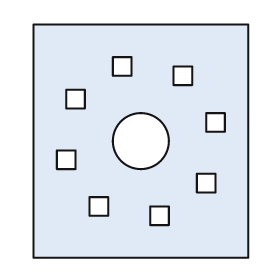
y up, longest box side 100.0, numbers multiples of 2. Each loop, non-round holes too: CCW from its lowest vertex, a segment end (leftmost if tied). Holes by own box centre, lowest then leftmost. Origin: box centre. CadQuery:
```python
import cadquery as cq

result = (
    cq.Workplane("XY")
    .moveTo(-46.0, -50.0)
    .lineTo(46.0, -50.0)
    .lineTo(46.0, 50.0)
    .lineTo(-46.0, 50.0)
    .close()
    .moveTo(4.0, -36.0)
    .lineTo(12.0, -36.0)
    .lineTo(12.0, -28.0)
    .lineTo(4.0, -28.0)
    .close()
    .moveTo(-22.0, -32.0)
    .lineTo(-14.0, -32.0)
    .lineTo(-14.0, -24.0)
    .lineTo(-22.0, -24.0)
    .close()
    .moveTo(24.0, -22.0)
    .lineTo(32.0, -22.0)
    .lineTo(32.0, -14.0)
    .lineTo(24.0, -14.0)
    .close()
    .moveTo(-36.0, -12.0)
    .lineTo(-28.0, -12.0)
    .lineTo(-28.0, -4.0)
    .lineTo(-36.0, -4.0)
    .close()
    .moveTo(0.0, 0.0)
    .circle(12.0)
    .moveTo(28.0, 4.0)
    .lineTo(36.0, 4.0)
    .lineTo(36.0, 12.0)
    .lineTo(28.0, 12.0)
    .close()
    .moveTo(-32.0, 14.0)
    .lineTo(-24.0, 14.0)
    .lineTo(-24.0, 22.0)
    .lineTo(-32.0, 22.0)
    .close()
    .moveTo(14.0, 24.0)
    .lineTo(22.0, 24.0)
    .lineTo(22.0, 32.0)
    .lineTo(14.0, 32.0)
    .close()
    .moveTo(-12.0, 28.0)
    .lineTo(-4.0, 28.0)
    .lineTo(-4.0, 36.0)
    .lineTo(-12.0, 36.0)
    .close()
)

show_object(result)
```